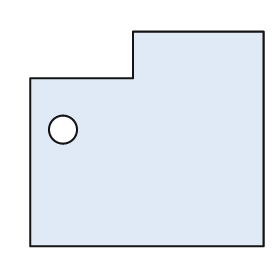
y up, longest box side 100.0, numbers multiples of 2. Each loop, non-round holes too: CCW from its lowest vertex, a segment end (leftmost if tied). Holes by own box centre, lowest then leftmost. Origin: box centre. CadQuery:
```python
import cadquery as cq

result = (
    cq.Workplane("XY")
    .moveTo(-50.0, -46.0)
    .lineTo(50.0, -46.0)
    .lineTo(50.0, 46.0)
    .lineTo(-6.0, 46.0)
    .lineTo(-6.0, 26.0)
    .lineTo(-50.0, 26.0)
    .close()
    .moveTo(-36.0, 4.0)
    .circle(6.0)
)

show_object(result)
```